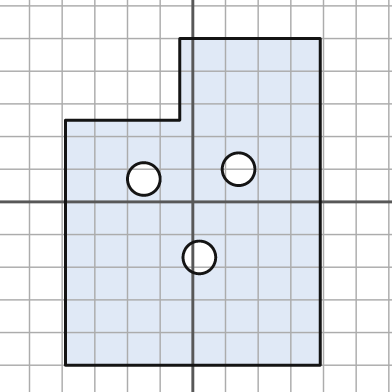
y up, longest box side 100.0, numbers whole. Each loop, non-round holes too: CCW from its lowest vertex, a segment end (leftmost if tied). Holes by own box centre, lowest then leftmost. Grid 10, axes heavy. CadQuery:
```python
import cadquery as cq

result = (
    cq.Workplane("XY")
    .moveTo(-39.0, -50.0)
    .lineTo(39.0, -50.0)
    .lineTo(39.0, 50.0)
    .lineTo(-4.0, 50.0)
    .lineTo(-4.0, 25.0)
    .lineTo(-39.0, 25.0)
    .close()
    .moveTo(2.0, -17.0)
    .circle(5.0)
    .moveTo(-15.0, 7.0)
    .circle(5.0)
    .moveTo(14.0, 10.0)
    .circle(5.0)
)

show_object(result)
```